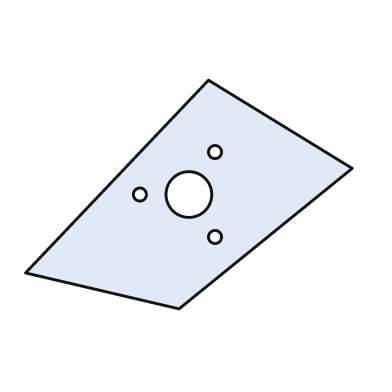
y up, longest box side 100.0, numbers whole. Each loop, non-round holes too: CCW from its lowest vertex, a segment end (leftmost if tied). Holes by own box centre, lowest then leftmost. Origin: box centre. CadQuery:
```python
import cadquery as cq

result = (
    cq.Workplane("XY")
    .moveTo(-3.0, -35.0)
    .lineTo(50.0, 8.0)
    .lineTo(6.0, 35.0)
    .lineTo(-50.0, -24.0)
    .close()
    .moveTo(8.0, -13.0)
    .circle(2.0)
    .moveTo(-15.0, 0.0)
    .circle(2.0)
    .moveTo(0.0, 0.0)
    .circle(7.0)
    .moveTo(8.0, 13.0)
    .circle(2.0)
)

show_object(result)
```